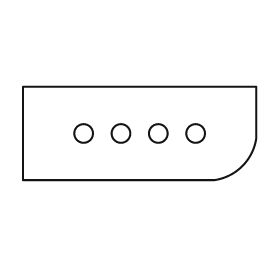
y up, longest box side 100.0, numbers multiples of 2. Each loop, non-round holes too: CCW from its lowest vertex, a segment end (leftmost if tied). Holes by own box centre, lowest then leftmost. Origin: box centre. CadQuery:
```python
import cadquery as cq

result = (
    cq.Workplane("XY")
    .moveTo(-50.0, -20.0)
    .lineTo(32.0, -20.0)
    .threePointArc((44.0, -14.0), (50.0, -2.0))
    .lineTo(50.0, 20.0)
    .lineTo(-50.0, 20.0)
    .close()
    .moveTo(-24.0, 0.0)
    .circle(4.0)
    .moveTo(-8.0, 0.0)
    .circle(4.0)
    .moveTo(8.0, 0.0)
    .circle(4.0)
    .moveTo(24.0, 0.0)
    .circle(4.0)
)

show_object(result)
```